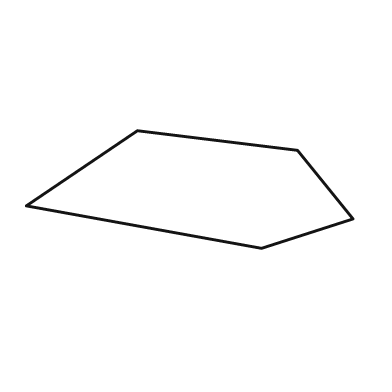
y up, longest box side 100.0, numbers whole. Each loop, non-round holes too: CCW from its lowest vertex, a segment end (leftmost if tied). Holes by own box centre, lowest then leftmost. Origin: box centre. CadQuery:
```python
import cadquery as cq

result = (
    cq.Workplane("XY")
    .moveTo(22.0, -18.0)
    .lineTo(50.0, -9.0)
    .lineTo(33.0, 12.0)
    .lineTo(-16.0, 18.0)
    .lineTo(-50.0, -5.0)
    .close()
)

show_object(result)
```